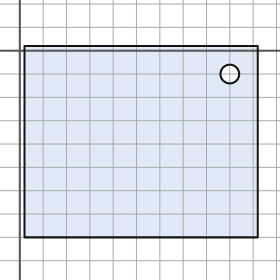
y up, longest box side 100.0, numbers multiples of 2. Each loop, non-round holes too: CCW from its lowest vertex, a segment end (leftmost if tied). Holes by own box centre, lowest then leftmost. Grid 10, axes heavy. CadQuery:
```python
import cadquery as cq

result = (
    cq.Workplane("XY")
    .moveTo(2.0, -80.0)
    .lineTo(102.0, -80.0)
    .lineTo(102.0, 2.0)
    .lineTo(2.0, 2.0)
    .close()
    .moveTo(90.0, -10.0)
    .circle(4.0)
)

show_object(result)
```